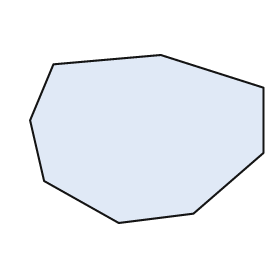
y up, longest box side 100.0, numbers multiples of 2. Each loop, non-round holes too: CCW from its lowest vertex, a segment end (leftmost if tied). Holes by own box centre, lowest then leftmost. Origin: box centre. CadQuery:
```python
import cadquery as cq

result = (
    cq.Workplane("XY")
    .moveTo(-12.0, -36.0)
    .lineTo(20.0, -32.0)
    .lineTo(50.0, -6.0)
    .lineTo(50.0, 22.0)
    .lineTo(6.0, 36.0)
    .lineTo(-40.0, 32.0)
    .lineTo(-50.0, 8.0)
    .lineTo(-44.0, -18.0)
    .close()
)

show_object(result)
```